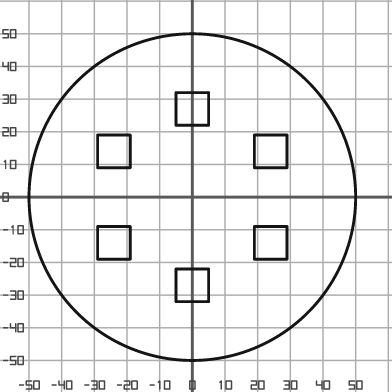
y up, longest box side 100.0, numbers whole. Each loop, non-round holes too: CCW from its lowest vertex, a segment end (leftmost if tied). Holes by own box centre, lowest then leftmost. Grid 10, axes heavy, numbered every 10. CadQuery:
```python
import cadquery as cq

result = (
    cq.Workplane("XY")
    .moveTo(0.0, 0.0)
    .circle(50.0)
    .moveTo(-5.0, -32.0)
    .lineTo(5.0, -32.0)
    .lineTo(5.0, -22.0)
    .lineTo(-5.0, -22.0)
    .close()
    .moveTo(-29.0, -19.0)
    .lineTo(-19.0, -19.0)
    .lineTo(-19.0, -9.0)
    .lineTo(-29.0, -9.0)
    .close()
    .moveTo(19.0, -19.0)
    .lineTo(29.0, -19.0)
    .lineTo(29.0, -9.0)
    .lineTo(19.0, -9.0)
    .close()
    .moveTo(-29.0, 9.0)
    .lineTo(-19.0, 9.0)
    .lineTo(-19.0, 19.0)
    .lineTo(-29.0, 19.0)
    .close()
    .moveTo(19.0, 9.0)
    .lineTo(29.0, 9.0)
    .lineTo(29.0, 19.0)
    .lineTo(19.0, 19.0)
    .close()
    .moveTo(-5.0, 22.0)
    .lineTo(5.0, 22.0)
    .lineTo(5.0, 32.0)
    .lineTo(-5.0, 32.0)
    .close()
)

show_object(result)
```